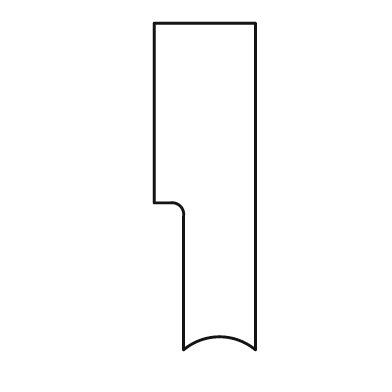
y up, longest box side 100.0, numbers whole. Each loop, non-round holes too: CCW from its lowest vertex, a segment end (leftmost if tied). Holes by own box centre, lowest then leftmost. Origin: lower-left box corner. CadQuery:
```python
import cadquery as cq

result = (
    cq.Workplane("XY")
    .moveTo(9.0, 0.0)
    .threePointArc((20.0, 4.0), (31.0, 0.0))
    .lineTo(31.0, 100.0)
    .lineTo(0.0, 100.0)
    .lineTo(0.0, 45.0)
    .lineTo(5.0, 45.0)
    .threePointArc((8.0, 44.0), (9.0, 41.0))
    .close()
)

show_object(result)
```